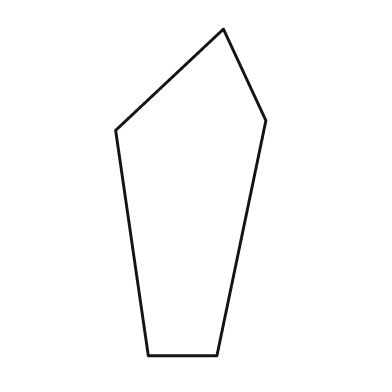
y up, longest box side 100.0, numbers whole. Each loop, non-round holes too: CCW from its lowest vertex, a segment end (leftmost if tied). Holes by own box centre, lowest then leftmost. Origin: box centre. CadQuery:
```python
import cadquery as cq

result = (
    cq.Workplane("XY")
    .moveTo(-13.0, -50.0)
    .lineTo(8.0, -50.0)
    .lineTo(23.0, 22.0)
    .lineTo(10.0, 50.0)
    .lineTo(-23.0, 19.0)
    .close()
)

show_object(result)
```